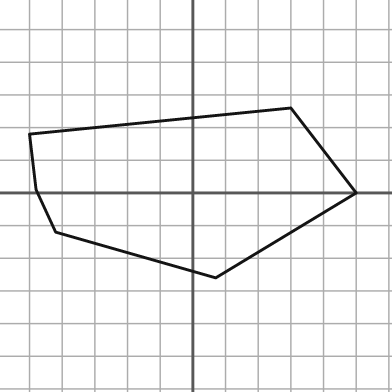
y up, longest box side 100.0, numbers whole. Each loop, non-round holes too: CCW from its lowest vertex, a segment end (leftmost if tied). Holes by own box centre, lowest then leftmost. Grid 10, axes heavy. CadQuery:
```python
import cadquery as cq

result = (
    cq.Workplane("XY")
    .moveTo(7.0, -26.0)
    .lineTo(50.0, 0.0)
    .lineTo(30.0, 26.0)
    .lineTo(-50.0, 18.0)
    .lineTo(-48.0, 1.0)
    .lineTo(-42.0, -12.0)
    .close()
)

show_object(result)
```